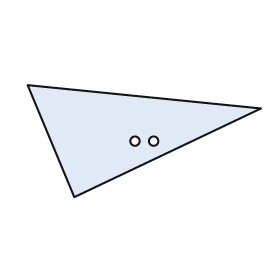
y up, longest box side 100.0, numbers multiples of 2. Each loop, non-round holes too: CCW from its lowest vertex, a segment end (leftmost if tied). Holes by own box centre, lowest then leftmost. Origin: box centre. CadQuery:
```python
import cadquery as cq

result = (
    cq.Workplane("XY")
    .moveTo(-30.0, -24.0)
    .lineTo(50.0, 14.0)
    .lineTo(-50.0, 24.0)
    .close()
    .moveTo(-4.0, 0.0)
    .circle(2.0)
    .moveTo(4.0, 0.0)
    .circle(2.0)
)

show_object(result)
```